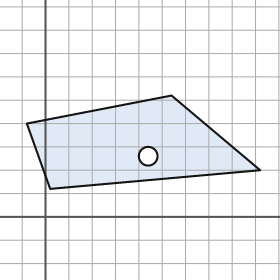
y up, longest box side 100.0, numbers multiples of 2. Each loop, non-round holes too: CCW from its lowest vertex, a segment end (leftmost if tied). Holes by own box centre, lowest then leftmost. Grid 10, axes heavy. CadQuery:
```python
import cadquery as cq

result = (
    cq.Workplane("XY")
    .moveTo(2.0, 12.0)
    .lineTo(92.0, 20.0)
    .lineTo(54.0, 52.0)
    .lineTo(-8.0, 40.0)
    .close()
    .moveTo(44.0, 26.0)
    .circle(4.0)
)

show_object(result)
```